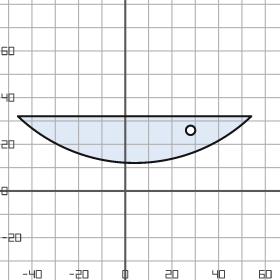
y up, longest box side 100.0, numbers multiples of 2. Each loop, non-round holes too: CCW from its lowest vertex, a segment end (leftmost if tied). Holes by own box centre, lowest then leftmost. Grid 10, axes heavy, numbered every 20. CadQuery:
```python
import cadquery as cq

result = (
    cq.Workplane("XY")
    .moveTo(-46.0, 32.0)
    .threePointArc((4.0, 12.0), (54.0, 32.0))
    .close()
    .moveTo(28.0, 26.0)
    .circle(2.0)
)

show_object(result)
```